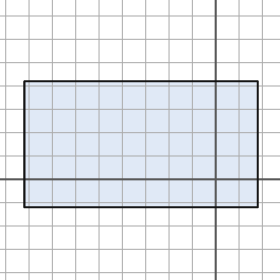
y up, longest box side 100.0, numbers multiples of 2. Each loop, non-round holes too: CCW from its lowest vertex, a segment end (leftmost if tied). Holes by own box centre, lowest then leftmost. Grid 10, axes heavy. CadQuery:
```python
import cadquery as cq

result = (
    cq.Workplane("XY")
    .moveTo(-82.0, -12.0)
    .lineTo(18.0, -12.0)
    .lineTo(18.0, 42.0)
    .lineTo(-82.0, 42.0)
    .close()
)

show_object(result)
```